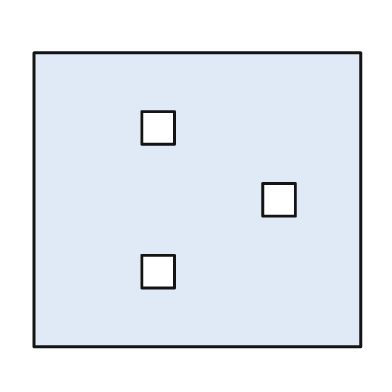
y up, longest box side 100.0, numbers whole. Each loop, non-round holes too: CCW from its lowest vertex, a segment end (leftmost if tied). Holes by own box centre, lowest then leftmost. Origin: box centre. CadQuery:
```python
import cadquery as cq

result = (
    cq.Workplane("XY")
    .moveTo(-50.0, -45.0)
    .lineTo(50.0, -45.0)
    .lineTo(50.0, 45.0)
    .lineTo(-50.0, 45.0)
    .close()
    .moveTo(-17.0, -27.0)
    .lineTo(-7.0, -27.0)
    .lineTo(-7.0, -17.0)
    .lineTo(-17.0, -17.0)
    .close()
    .moveTo(20.0, -5.0)
    .lineTo(30.0, -5.0)
    .lineTo(30.0, 5.0)
    .lineTo(20.0, 5.0)
    .close()
    .moveTo(-17.0, 17.0)
    .lineTo(-7.0, 17.0)
    .lineTo(-7.0, 27.0)
    .lineTo(-17.0, 27.0)
    .close()
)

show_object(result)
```